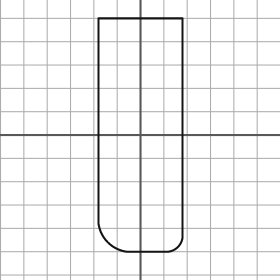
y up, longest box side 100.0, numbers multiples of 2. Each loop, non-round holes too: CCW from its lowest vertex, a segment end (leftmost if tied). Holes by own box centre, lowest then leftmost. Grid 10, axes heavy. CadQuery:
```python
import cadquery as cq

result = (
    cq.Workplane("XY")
    .moveTo(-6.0, -50.0)
    .lineTo(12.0, -50.0)
    .threePointArc((16.0, -48.0), (18.0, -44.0))
    .lineTo(18.0, 50.0)
    .lineTo(-18.0, 50.0)
    .lineTo(-18.0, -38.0)
    .threePointArc((-14.0, -46.0), (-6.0, -50.0))
    .close()
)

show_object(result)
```